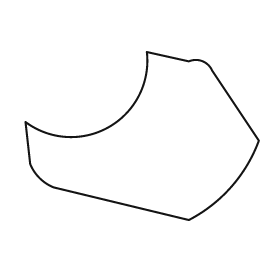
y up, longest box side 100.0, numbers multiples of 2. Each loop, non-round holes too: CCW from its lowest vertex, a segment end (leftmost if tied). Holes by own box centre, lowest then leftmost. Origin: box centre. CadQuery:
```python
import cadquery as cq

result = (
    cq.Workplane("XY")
    .moveTo(20.0, -36.0)
    .threePointArc((38.0, -22.0), (50.0, -2.0))
    .lineTo(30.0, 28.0)
    .threePointArc((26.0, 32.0), (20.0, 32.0))
    .lineTo(2.0, 36.0)
    .threePointArc((-14.0, 4.0), (-50.0, 6.0))
    .lineTo(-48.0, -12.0)
    .threePointArc((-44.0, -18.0), (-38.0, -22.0))
    .close()
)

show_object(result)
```